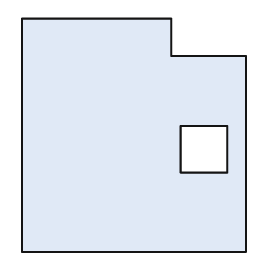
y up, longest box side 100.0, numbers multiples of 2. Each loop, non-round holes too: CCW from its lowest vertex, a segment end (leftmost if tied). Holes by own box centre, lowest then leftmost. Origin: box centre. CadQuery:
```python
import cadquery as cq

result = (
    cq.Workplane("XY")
    .moveTo(-48.0, -50.0)
    .lineTo(48.0, -50.0)
    .lineTo(48.0, 34.0)
    .lineTo(16.0, 34.0)
    .lineTo(16.0, 50.0)
    .lineTo(-48.0, 50.0)
    .close()
    .moveTo(20.0, -16.0)
    .lineTo(40.0, -16.0)
    .lineTo(40.0, 4.0)
    .lineTo(20.0, 4.0)
    .close()
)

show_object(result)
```